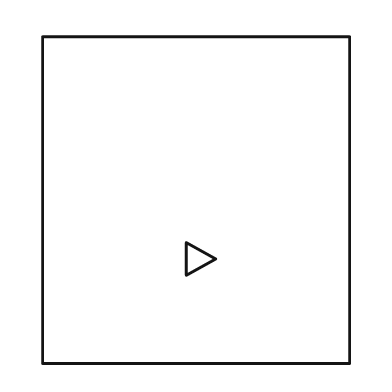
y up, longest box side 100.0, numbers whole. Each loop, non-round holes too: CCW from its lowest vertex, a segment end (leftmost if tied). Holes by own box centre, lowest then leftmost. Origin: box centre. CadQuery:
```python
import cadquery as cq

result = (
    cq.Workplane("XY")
    .moveTo(-47.0, -50.0)
    .lineTo(47.0, -50.0)
    .lineTo(47.0, 50.0)
    .lineTo(-47.0, 50.0)
    .close()
    .moveTo(-3.0, -23.0)
    .lineTo(6.0, -18.0)
    .lineTo(-3.0, -13.0)
    .close()
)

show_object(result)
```